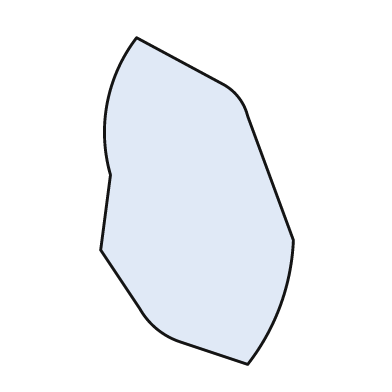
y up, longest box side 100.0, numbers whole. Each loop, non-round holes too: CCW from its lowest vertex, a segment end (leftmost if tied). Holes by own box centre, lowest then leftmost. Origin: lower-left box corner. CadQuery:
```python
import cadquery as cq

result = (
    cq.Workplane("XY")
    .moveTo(45.0, 0.0)
    .threePointArc((55.0, 18.0), (59.0, 38.0))
    .lineTo(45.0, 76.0)
    .threePointArc((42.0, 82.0), (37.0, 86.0))
    .lineTo(11.0, 100.0)
    .threePointArc((2.0, 80.0), (3.0, 58.0))
    .lineTo(0.0, 35.0)
    .lineTo(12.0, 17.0)
    .threePointArc((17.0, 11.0), (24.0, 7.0))
    .close()
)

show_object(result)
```